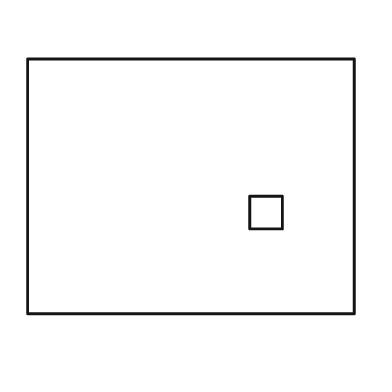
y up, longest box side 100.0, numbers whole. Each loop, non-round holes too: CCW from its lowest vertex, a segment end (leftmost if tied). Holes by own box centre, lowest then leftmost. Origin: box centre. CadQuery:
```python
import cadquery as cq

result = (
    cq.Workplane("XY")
    .moveTo(-50.0, -39.0)
    .lineTo(50.0, -39.0)
    .lineTo(50.0, 39.0)
    .lineTo(-50.0, 39.0)
    .close()
    .moveTo(18.0, -13.0)
    .lineTo(28.0, -13.0)
    .lineTo(28.0, -3.0)
    .lineTo(18.0, -3.0)
    .close()
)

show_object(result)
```